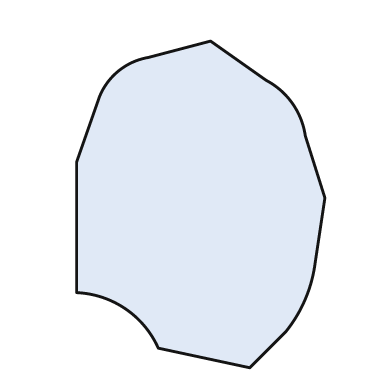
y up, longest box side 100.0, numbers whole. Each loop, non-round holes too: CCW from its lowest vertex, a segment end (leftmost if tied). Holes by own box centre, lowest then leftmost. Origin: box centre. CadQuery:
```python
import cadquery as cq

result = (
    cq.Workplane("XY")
    .moveTo(15.0, -50.0)
    .lineTo(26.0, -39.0)
    .threePointArc((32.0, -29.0), (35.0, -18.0))
    .lineTo(38.0, 2.0)
    .lineTo(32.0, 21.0)
    .threePointArc((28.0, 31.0), (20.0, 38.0))
    .lineTo(3.0, 50.0)
    .lineTo(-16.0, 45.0)
    .threePointArc((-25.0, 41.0), (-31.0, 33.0))
    .lineTo(-38.0, 13.0)
    .lineTo(-38.0, -27.0)
    .threePointArc((-23.0, -32.0), (-13.0, -44.0))
    .close()
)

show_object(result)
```